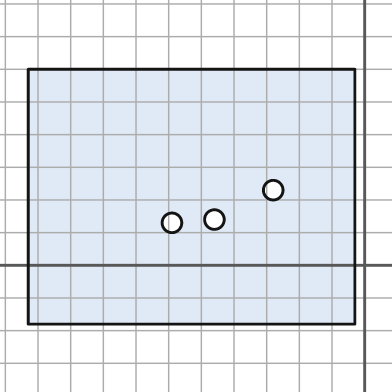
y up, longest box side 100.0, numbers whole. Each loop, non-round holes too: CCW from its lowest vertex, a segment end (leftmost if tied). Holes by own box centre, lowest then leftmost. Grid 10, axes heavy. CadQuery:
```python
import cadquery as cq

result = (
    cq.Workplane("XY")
    .moveTo(-103.0, -18.0)
    .lineTo(-3.0, -18.0)
    .lineTo(-3.0, 60.0)
    .lineTo(-103.0, 60.0)
    .close()
    .moveTo(-59.0, 13.0)
    .circle(3.0)
    .moveTo(-46.0, 14.0)
    .circle(3.0)
    .moveTo(-28.0, 23.0)
    .circle(3.0)
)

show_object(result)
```